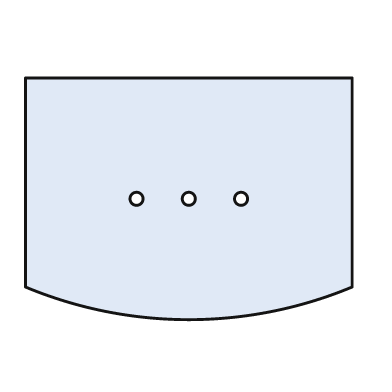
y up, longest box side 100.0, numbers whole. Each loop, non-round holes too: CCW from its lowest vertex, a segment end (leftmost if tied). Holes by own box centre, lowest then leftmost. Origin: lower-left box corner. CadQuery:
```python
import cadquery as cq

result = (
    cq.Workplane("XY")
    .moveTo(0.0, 10.0)
    .threePointArc((50.0, 0.0), (100.0, 10.0))
    .lineTo(100.0, 74.0)
    .lineTo(0.0, 74.0)
    .close()
    .moveTo(34.0, 37.0)
    .circle(2.0)
    .moveTo(50.0, 37.0)
    .circle(2.0)
    .moveTo(66.0, 37.0)
    .circle(2.0)
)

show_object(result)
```